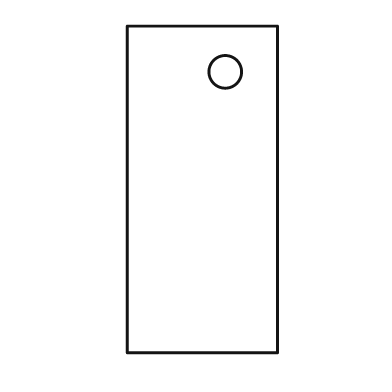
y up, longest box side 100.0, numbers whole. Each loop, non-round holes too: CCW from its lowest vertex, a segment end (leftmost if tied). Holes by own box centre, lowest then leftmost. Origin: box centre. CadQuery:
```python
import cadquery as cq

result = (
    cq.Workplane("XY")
    .moveTo(-23.0, -50.0)
    .lineTo(23.0, -50.0)
    .lineTo(23.0, 50.0)
    .lineTo(-23.0, 50.0)
    .close()
    .moveTo(7.0, 36.0)
    .circle(5.0)
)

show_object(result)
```